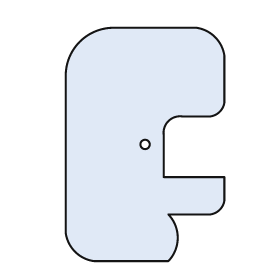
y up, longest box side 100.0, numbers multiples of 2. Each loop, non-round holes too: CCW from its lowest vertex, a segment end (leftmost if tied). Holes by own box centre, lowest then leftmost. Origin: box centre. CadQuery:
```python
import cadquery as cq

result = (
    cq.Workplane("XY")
    .moveTo(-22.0, -50.0)
    .lineTo(10.0, -50.0)
    .threePointArc((14.0, -40.0), (10.0, -30.0))
    .lineTo(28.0, -30.0)
    .threePointArc((32.0, -28.0), (34.0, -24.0))
    .lineTo(34.0, -14.0)
    .lineTo(8.0, -14.0)
    .lineTo(8.0, 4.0)
    .threePointArc((10.0, 10.0), (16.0, 12.0))
    .lineTo(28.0, 12.0)
    .threePointArc((32.0, 14.0), (34.0, 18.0))
    .lineTo(34.0, 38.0)
    .threePointArc((30.0, 46.0), (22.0, 50.0))
    .lineTo(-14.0, 50.0)
    .threePointArc((-28.0, 44.0), (-34.0, 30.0))
    .lineTo(-34.0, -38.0)
    .threePointArc((-30.0, -46.0), (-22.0, -50.0))
    .close()
    .moveTo(0.0, 0.0)
    .circle(2.0)
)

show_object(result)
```